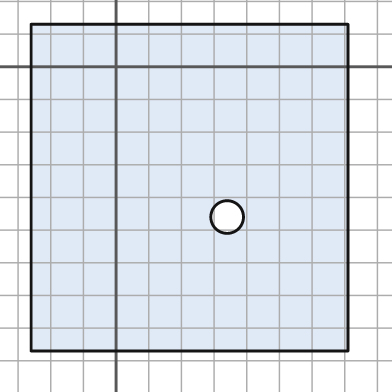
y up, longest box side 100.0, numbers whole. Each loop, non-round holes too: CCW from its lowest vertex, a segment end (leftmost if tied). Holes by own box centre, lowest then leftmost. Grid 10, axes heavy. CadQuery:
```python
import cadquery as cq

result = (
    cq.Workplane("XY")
    .moveTo(-26.0, -87.0)
    .lineTo(71.0, -87.0)
    .lineTo(71.0, 13.0)
    .lineTo(-26.0, 13.0)
    .close()
    .moveTo(34.0, -46.0)
    .circle(5.0)
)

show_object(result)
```